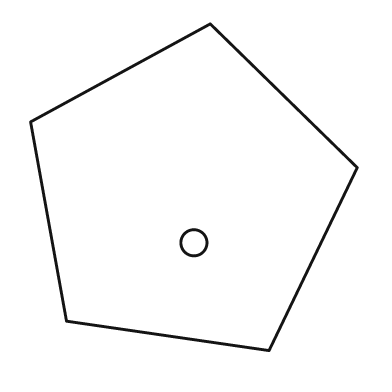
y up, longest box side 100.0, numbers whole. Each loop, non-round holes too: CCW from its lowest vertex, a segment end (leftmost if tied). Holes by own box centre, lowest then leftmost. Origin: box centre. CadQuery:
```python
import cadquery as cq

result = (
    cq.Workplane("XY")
    .moveTo(23.0, -50.0)
    .lineTo(50.0, 6.0)
    .lineTo(5.0, 50.0)
    .lineTo(-50.0, 20.0)
    .lineTo(-39.0, -41.0)
    .close()
    .moveTo(0.0, -17.0)
    .circle(4.0)
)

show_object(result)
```